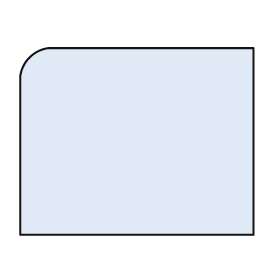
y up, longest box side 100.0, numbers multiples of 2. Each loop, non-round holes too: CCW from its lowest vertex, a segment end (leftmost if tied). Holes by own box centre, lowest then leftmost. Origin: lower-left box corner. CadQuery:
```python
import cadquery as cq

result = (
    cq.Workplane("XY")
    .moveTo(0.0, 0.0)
    .lineTo(100.0, 0.0)
    .lineTo(100.0, 80.0)
    .lineTo(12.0, 80.0)
    .threePointArc((4.0, 76.0), (0.0, 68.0))
    .close()
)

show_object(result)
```